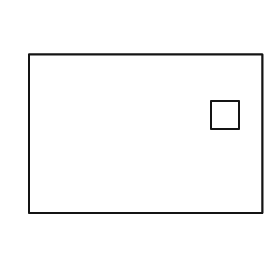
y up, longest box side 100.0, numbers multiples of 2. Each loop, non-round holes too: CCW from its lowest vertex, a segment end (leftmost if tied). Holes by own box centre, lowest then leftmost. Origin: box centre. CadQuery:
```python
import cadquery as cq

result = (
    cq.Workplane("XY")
    .moveTo(-50.0, -34.0)
    .lineTo(50.0, -34.0)
    .lineTo(50.0, 34.0)
    .lineTo(-50.0, 34.0)
    .close()
    .moveTo(28.0, 2.0)
    .lineTo(40.0, 2.0)
    .lineTo(40.0, 14.0)
    .lineTo(28.0, 14.0)
    .close()
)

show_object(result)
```